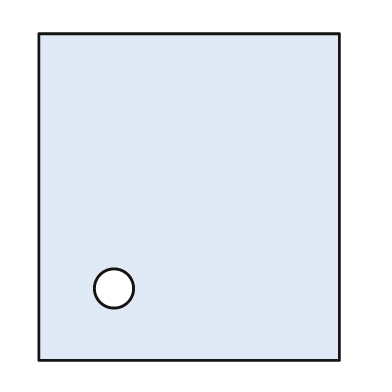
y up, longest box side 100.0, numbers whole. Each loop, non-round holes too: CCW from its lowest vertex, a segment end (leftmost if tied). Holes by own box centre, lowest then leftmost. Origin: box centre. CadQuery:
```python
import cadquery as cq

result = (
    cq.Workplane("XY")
    .moveTo(-46.0, -50.0)
    .lineTo(46.0, -50.0)
    .lineTo(46.0, 50.0)
    .lineTo(-46.0, 50.0)
    .close()
    .moveTo(-23.0, -28.0)
    .circle(6.0)
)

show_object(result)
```